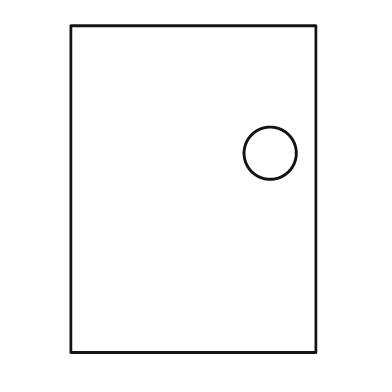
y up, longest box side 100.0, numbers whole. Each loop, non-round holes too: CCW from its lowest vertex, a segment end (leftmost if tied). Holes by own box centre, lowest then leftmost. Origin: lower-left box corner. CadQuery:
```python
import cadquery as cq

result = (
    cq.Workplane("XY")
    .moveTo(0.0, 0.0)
    .lineTo(75.0, 0.0)
    .lineTo(75.0, 100.0)
    .lineTo(0.0, 100.0)
    .close()
    .moveTo(61.0, 61.0)
    .circle(8.0)
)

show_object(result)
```